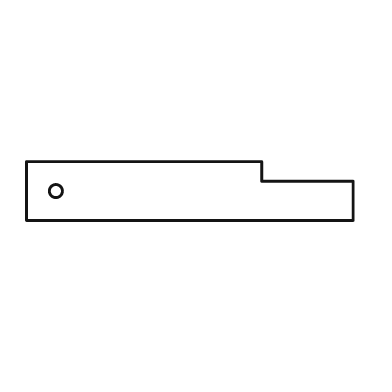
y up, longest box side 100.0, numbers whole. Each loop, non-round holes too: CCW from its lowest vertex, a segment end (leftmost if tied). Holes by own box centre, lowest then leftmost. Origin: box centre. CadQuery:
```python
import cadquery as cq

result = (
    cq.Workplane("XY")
    .moveTo(-50.0, -9.0)
    .lineTo(50.0, -9.0)
    .lineTo(50.0, 3.0)
    .lineTo(22.0, 3.0)
    .lineTo(22.0, 9.0)
    .lineTo(-50.0, 9.0)
    .close()
    .moveTo(-41.0, 0.0)
    .circle(2.0)
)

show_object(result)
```